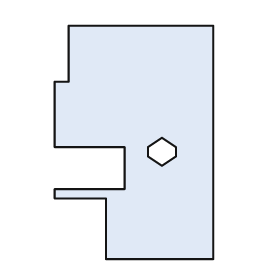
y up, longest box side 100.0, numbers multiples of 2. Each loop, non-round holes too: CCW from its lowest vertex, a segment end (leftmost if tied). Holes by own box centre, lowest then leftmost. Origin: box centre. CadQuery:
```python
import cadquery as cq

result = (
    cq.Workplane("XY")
    .moveTo(-12.0, -50.0)
    .lineTo(34.0, -50.0)
    .lineTo(34.0, 50.0)
    .lineTo(-28.0, 50.0)
    .lineTo(-28.0, 26.0)
    .lineTo(-34.0, 26.0)
    .lineTo(-34.0, -2.0)
    .lineTo(-4.0, -2.0)
    .lineTo(-4.0, -20.0)
    .lineTo(-34.0, -20.0)
    .lineTo(-34.0, -24.0)
    .lineTo(-12.0, -24.0)
    .close()
    .moveTo(12.0, -10.0)
    .lineTo(18.0, -6.0)
    .lineTo(18.0, -2.0)
    .lineTo(12.0, 2.0)
    .lineTo(6.0, -2.0)
    .lineTo(6.0, -6.0)
    .close()
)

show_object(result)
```